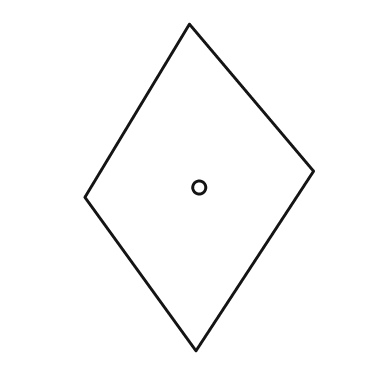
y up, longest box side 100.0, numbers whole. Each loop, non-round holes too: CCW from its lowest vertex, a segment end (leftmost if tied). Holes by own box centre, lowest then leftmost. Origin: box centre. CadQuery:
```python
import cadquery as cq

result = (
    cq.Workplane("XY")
    .moveTo(-1.0, -50.0)
    .lineTo(35.0, 5.0)
    .lineTo(-3.0, 50.0)
    .lineTo(-35.0, -3.0)
    .close()
    .moveTo(0.0, 0.0)
    .circle(2.0)
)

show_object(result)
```